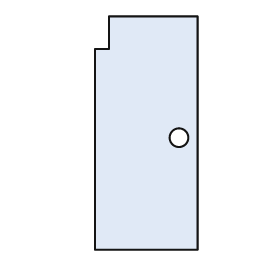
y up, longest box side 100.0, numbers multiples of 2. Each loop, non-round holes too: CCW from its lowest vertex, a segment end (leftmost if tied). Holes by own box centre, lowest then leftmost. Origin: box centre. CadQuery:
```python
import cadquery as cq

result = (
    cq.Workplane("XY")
    .moveTo(-22.0, -50.0)
    .lineTo(22.0, -50.0)
    .lineTo(22.0, 50.0)
    .lineTo(-16.0, 50.0)
    .lineTo(-16.0, 36.0)
    .lineTo(-22.0, 36.0)
    .close()
    .moveTo(14.0, -2.0)
    .circle(4.0)
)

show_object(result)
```